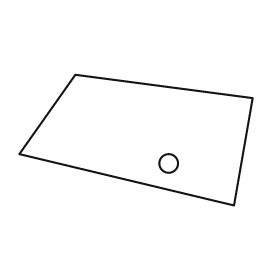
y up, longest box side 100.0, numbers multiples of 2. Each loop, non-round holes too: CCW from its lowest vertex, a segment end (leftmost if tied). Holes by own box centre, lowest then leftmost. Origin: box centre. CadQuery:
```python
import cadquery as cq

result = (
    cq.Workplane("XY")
    .moveTo(42.0, -28.0)
    .lineTo(50.0, 18.0)
    .lineTo(-26.0, 28.0)
    .lineTo(-50.0, -6.0)
    .close()
    .moveTo(14.0, -10.0)
    .circle(4.0)
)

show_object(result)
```